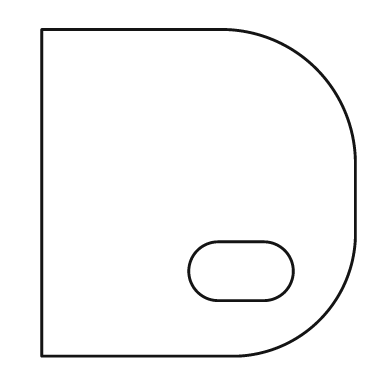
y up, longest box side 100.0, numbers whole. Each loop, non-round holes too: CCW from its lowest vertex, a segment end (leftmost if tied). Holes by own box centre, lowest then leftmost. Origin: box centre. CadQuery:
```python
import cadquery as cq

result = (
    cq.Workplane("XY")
    .moveTo(-48.0, -50.0)
    .lineTo(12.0, -50.0)
    .threePointArc((37.0, -39.0), (48.0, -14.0))
    .lineTo(48.0, 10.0)
    .threePointArc((36.0, 38.0), (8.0, 50.0))
    .lineTo(-48.0, 50.0)
    .close()
    .moveTo(6.0, -33.0)
    .lineTo(20.0, -33.0)
    .threePointArc((29.0, -24.0), (20.0, -15.0))
    .lineTo(6.0, -15.0)
    .threePointArc((-3.0, -24.0), (6.0, -33.0))
    .close()
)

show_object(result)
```